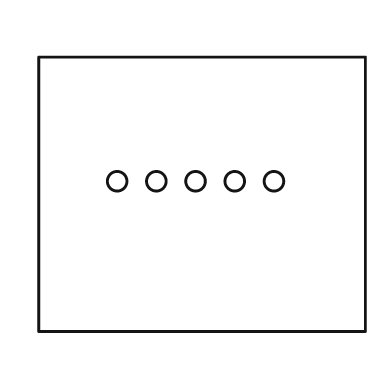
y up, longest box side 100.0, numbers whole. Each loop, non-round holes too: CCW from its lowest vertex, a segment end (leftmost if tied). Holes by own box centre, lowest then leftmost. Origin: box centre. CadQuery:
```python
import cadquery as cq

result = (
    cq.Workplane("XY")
    .moveTo(-50.0, -42.0)
    .lineTo(50.0, -42.0)
    .lineTo(50.0, 42.0)
    .lineTo(-50.0, 42.0)
    .close()
    .moveTo(-26.0, 4.0)
    .circle(3.0)
    .moveTo(-14.0, 4.0)
    .circle(3.0)
    .moveTo(-2.0, 4.0)
    .circle(3.0)
    .moveTo(10.0, 4.0)
    .circle(3.0)
    .moveTo(22.0, 4.0)
    .circle(3.0)
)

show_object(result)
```